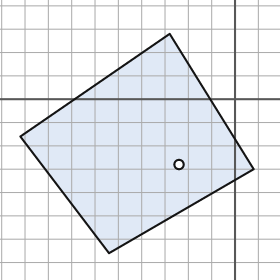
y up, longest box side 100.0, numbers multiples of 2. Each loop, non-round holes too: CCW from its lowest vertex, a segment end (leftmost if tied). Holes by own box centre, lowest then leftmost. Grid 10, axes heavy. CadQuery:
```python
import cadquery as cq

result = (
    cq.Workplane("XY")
    .moveTo(-54.0, -66.0)
    .lineTo(8.0, -30.0)
    .lineTo(-28.0, 28.0)
    .lineTo(-92.0, -16.0)
    .close()
    .moveTo(-24.0, -28.0)
    .circle(2.0)
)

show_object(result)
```